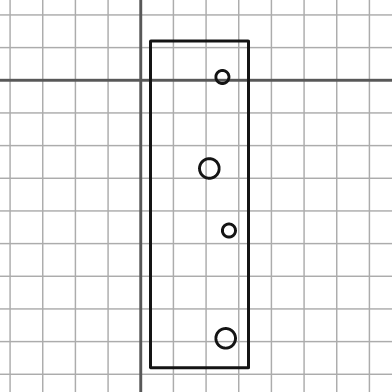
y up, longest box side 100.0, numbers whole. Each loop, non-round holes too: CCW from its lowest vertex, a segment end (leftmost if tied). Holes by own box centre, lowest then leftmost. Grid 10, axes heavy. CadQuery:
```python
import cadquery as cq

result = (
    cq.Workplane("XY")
    .moveTo(3.0, -88.0)
    .lineTo(33.0, -88.0)
    .lineTo(33.0, 12.0)
    .lineTo(3.0, 12.0)
    .close()
    .moveTo(26.0, -79.0)
    .circle(3.0)
    .moveTo(27.0, -46.0)
    .circle(2.0)
    .moveTo(21.0, -27.0)
    .circle(3.0)
    .moveTo(25.0, 1.0)
    .circle(2.0)
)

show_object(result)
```